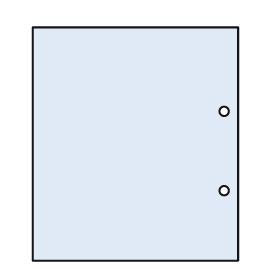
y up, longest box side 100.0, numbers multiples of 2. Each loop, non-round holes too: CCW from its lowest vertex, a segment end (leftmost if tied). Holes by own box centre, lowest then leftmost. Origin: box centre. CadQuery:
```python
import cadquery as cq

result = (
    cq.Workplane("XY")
    .moveTo(-44.0, -50.0)
    .lineTo(44.0, -50.0)
    .lineTo(44.0, 50.0)
    .lineTo(-44.0, 50.0)
    .close()
    .moveTo(38.0, -20.0)
    .circle(2.0)
    .moveTo(38.0, 14.0)
    .circle(2.0)
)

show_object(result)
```